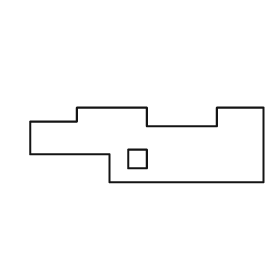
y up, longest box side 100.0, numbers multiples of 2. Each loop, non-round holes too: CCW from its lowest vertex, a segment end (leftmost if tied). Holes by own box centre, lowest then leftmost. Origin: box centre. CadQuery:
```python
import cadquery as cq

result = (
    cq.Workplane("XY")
    .moveTo(-16.0, -16.0)
    .lineTo(50.0, -16.0)
    .lineTo(50.0, 16.0)
    .lineTo(30.0, 16.0)
    .lineTo(30.0, 8.0)
    .lineTo(0.0, 8.0)
    .lineTo(0.0, 16.0)
    .lineTo(-30.0, 16.0)
    .lineTo(-30.0, 10.0)
    .lineTo(-50.0, 10.0)
    .lineTo(-50.0, -4.0)
    .lineTo(-16.0, -4.0)
    .close()
    .moveTo(-8.0, -10.0)
    .lineTo(0.0, -10.0)
    .lineTo(0.0, -2.0)
    .lineTo(-8.0, -2.0)
    .close()
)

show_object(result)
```